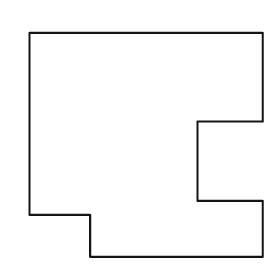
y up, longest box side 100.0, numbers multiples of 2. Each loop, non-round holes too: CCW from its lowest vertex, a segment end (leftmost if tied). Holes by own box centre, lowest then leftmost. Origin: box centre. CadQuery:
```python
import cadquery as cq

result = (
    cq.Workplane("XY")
    .moveTo(-24.0, -48.0)
    .lineTo(50.0, -48.0)
    .lineTo(50.0, -24.0)
    .lineTo(22.0, -24.0)
    .lineTo(22.0, 10.0)
    .lineTo(50.0, 10.0)
    .lineTo(50.0, 48.0)
    .lineTo(-50.0, 48.0)
    .lineTo(-50.0, -30.0)
    .lineTo(-24.0, -30.0)
    .close()
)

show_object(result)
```